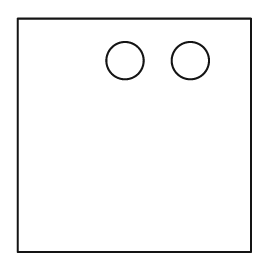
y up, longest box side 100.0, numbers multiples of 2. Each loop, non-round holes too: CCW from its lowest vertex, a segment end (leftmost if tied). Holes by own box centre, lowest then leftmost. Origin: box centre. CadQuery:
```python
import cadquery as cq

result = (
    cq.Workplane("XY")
    .moveTo(-50.0, -50.0)
    .lineTo(50.0, -50.0)
    .lineTo(50.0, 50.0)
    .lineTo(-50.0, 50.0)
    .close()
    .moveTo(-4.0, 32.0)
    .circle(8.0)
    .moveTo(24.0, 32.0)
    .circle(8.0)
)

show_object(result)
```